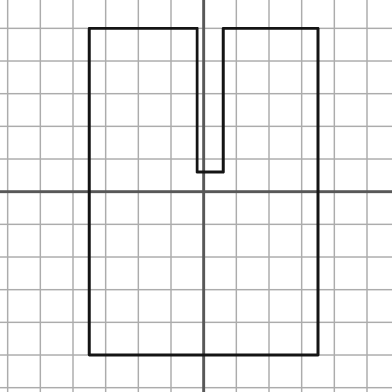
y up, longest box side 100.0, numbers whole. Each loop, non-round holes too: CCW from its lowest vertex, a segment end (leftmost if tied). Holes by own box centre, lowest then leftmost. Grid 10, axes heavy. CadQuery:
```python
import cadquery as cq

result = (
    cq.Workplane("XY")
    .moveTo(-35.0, -50.0)
    .lineTo(35.0, -50.0)
    .lineTo(35.0, 50.0)
    .lineTo(6.0, 50.0)
    .lineTo(6.0, 6.0)
    .lineTo(-2.0, 6.0)
    .lineTo(-2.0, 50.0)
    .lineTo(-35.0, 50.0)
    .close()
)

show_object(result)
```